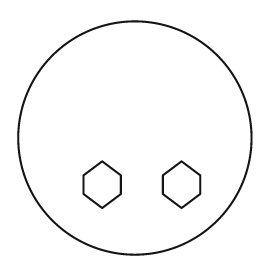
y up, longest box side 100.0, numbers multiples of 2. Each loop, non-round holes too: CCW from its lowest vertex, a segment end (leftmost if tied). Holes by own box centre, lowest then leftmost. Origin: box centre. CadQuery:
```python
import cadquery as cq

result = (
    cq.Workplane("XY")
    .moveTo(0.0, 0.0)
    .circle(50.0)
    .moveTo(-14.0, -30.0)
    .lineTo(-6.0, -24.0)
    .lineTo(-6.0, -16.0)
    .lineTo(-14.0, -10.0)
    .lineTo(-22.0, -16.0)
    .lineTo(-22.0, -24.0)
    .close()
    .moveTo(20.0, -30.0)
    .lineTo(28.0, -24.0)
    .lineTo(28.0, -16.0)
    .lineTo(20.0, -10.0)
    .lineTo(12.0, -16.0)
    .lineTo(12.0, -24.0)
    .close()
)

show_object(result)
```